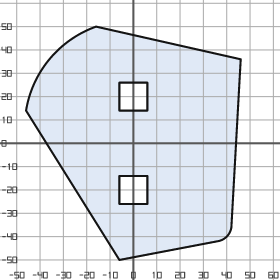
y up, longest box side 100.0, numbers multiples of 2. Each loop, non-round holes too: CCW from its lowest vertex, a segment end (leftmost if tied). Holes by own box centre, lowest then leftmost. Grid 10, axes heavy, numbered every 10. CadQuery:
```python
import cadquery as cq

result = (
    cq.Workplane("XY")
    .moveTo(-6.0, -50.0)
    .lineTo(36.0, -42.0)
    .threePointArc((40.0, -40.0), (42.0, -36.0))
    .lineTo(46.0, 36.0)
    .lineTo(-16.0, 50.0)
    .threePointArc((-36.0, 36.0), (-46.0, 14.0))
    .close()
    .moveTo(-6.0, -26.0)
    .lineTo(6.0, -26.0)
    .lineTo(6.0, -14.0)
    .lineTo(-6.0, -14.0)
    .close()
    .moveTo(-6.0, 14.0)
    .lineTo(6.0, 14.0)
    .lineTo(6.0, 26.0)
    .lineTo(-6.0, 26.0)
    .close()
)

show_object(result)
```